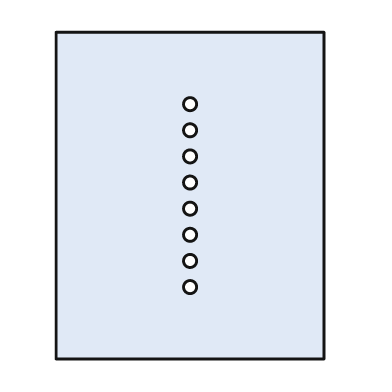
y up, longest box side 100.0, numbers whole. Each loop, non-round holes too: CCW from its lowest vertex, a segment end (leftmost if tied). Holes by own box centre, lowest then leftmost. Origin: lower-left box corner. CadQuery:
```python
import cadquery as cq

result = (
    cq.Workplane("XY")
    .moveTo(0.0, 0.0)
    .lineTo(82.0, 0.0)
    .lineTo(82.0, 100.0)
    .lineTo(0.0, 100.0)
    .close()
    .moveTo(41.0, 22.0)
    .circle(2.0)
    .moveTo(41.0, 30.0)
    .circle(2.0)
    .moveTo(41.0, 38.0)
    .circle(2.0)
    .moveTo(41.0, 46.0)
    .circle(2.0)
    .moveTo(41.0, 54.0)
    .circle(2.0)
    .moveTo(41.0, 62.0)
    .circle(2.0)
    .moveTo(41.0, 70.0)
    .circle(2.0)
    .moveTo(41.0, 78.0)
    .circle(2.0)
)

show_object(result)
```